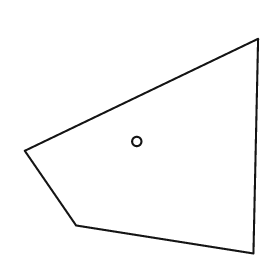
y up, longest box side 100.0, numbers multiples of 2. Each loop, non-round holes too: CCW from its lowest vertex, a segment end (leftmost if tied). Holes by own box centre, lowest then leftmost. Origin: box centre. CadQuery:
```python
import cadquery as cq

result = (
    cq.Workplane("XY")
    .moveTo(48.0, -46.0)
    .lineTo(50.0, 46.0)
    .lineTo(-50.0, -2.0)
    .lineTo(-28.0, -34.0)
    .close()
    .moveTo(-2.0, 2.0)
    .circle(2.0)
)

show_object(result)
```